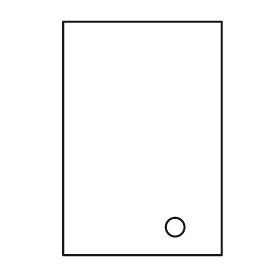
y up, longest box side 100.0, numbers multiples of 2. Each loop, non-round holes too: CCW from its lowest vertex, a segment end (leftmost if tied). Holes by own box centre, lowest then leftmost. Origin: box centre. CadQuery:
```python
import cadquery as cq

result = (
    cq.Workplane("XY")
    .moveTo(-34.0, -50.0)
    .lineTo(34.0, -50.0)
    .lineTo(34.0, 50.0)
    .lineTo(-34.0, 50.0)
    .close()
    .moveTo(14.0, -38.0)
    .circle(4.0)
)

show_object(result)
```